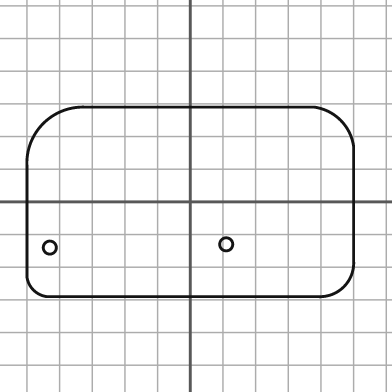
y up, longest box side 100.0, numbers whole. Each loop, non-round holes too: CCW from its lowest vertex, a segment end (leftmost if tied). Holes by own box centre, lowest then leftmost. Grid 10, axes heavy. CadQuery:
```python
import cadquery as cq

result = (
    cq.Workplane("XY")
    .moveTo(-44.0, -29.0)
    .lineTo(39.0, -29.0)
    .threePointArc((47.0, -26.0), (50.0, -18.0))
    .lineTo(50.0, 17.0)
    .threePointArc((46.0, 25.0), (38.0, 29.0))
    .lineTo(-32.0, 29.0)
    .threePointArc((-45.0, 24.0), (-50.0, 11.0))
    .lineTo(-50.0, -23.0)
    .threePointArc((-48.0, -27.0), (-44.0, -29.0))
    .close()
    .moveTo(-43.0, -14.0)
    .circle(2.0)
    .moveTo(11.0, -13.0)
    .circle(2.0)
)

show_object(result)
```